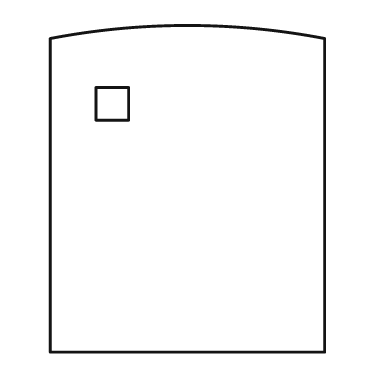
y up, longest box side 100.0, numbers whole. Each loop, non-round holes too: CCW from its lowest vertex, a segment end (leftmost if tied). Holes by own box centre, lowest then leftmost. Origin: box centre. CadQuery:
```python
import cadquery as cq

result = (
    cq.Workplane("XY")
    .moveTo(-42.0, -50.0)
    .lineTo(42.0, -50.0)
    .lineTo(42.0, 46.0)
    .threePointArc((0.0, 50.0), (-42.0, 46.0))
    .close()
    .moveTo(-28.0, 21.0)
    .lineTo(-18.0, 21.0)
    .lineTo(-18.0, 31.0)
    .lineTo(-28.0, 31.0)
    .close()
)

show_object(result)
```